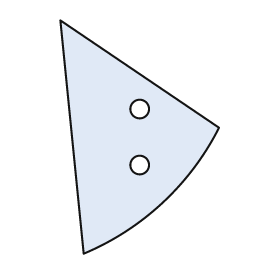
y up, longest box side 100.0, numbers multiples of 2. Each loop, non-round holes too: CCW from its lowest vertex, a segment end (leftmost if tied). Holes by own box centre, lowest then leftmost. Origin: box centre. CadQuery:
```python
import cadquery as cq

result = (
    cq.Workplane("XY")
    .moveTo(-24.0, -50.0)
    .threePointArc((10.0, -28.0), (34.0, 4.0))
    .lineTo(-34.0, 50.0)
    .close()
    .moveTo(0.0, -12.0)
    .circle(4.0)
    .moveTo(0.0, 12.0)
    .circle(4.0)
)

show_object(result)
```